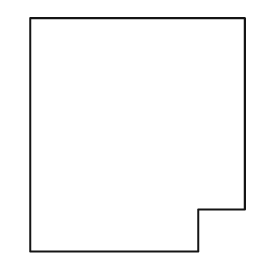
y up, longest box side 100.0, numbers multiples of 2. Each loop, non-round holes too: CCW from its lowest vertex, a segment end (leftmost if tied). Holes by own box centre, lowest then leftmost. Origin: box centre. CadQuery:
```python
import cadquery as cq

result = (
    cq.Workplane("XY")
    .moveTo(-46.0, -50.0)
    .lineTo(26.0, -50.0)
    .lineTo(26.0, -32.0)
    .lineTo(46.0, -32.0)
    .lineTo(46.0, 50.0)
    .lineTo(-46.0, 50.0)
    .close()
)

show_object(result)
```